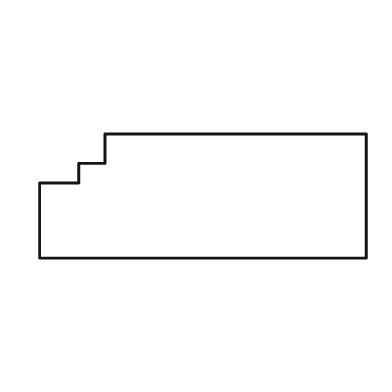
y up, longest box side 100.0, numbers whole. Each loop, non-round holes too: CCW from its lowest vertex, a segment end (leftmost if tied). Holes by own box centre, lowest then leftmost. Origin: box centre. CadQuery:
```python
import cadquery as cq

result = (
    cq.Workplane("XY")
    .moveTo(-50.0, -19.0)
    .lineTo(50.0, -19.0)
    .lineTo(50.0, 19.0)
    .lineTo(-30.0, 19.0)
    .lineTo(-30.0, 10.0)
    .lineTo(-38.0, 10.0)
    .lineTo(-38.0, 4.0)
    .lineTo(-50.0, 4.0)
    .close()
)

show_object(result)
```